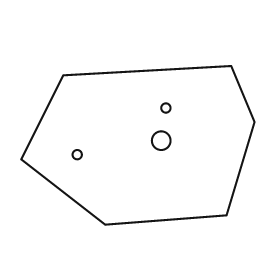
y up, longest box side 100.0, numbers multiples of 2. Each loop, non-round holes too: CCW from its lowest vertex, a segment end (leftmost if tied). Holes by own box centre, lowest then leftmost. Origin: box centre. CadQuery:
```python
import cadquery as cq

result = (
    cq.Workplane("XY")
    .moveTo(-14.0, -34.0)
    .lineTo(38.0, -30.0)
    .lineTo(50.0, 10.0)
    .lineTo(40.0, 34.0)
    .lineTo(-32.0, 30.0)
    .lineTo(-50.0, -6.0)
    .close()
    .moveTo(-26.0, -4.0)
    .circle(2.0)
    .moveTo(10.0, 2.0)
    .circle(4.0)
    .moveTo(12.0, 16.0)
    .circle(2.0)
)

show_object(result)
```